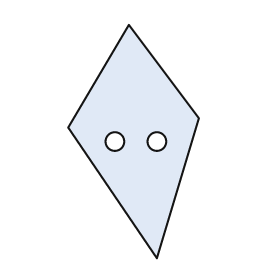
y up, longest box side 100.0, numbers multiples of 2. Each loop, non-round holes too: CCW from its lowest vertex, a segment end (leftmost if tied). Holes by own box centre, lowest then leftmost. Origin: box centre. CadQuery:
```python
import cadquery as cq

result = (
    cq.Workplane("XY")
    .moveTo(10.0, -50.0)
    .lineTo(28.0, 10.0)
    .lineTo(-2.0, 50.0)
    .lineTo(-28.0, 6.0)
    .close()
    .moveTo(-8.0, 0.0)
    .circle(4.0)
    .moveTo(10.0, 0.0)
    .circle(4.0)
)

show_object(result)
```